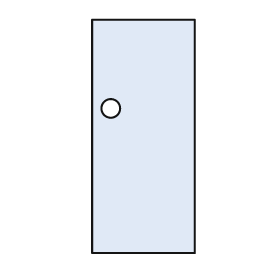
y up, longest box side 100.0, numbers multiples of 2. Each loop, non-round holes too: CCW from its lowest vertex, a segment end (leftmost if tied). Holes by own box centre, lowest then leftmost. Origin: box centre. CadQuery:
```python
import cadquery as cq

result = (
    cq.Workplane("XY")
    .moveTo(-22.0, -50.0)
    .lineTo(22.0, -50.0)
    .lineTo(22.0, 50.0)
    .lineTo(-22.0, 50.0)
    .close()
    .moveTo(-14.0, 12.0)
    .circle(4.0)
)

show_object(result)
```